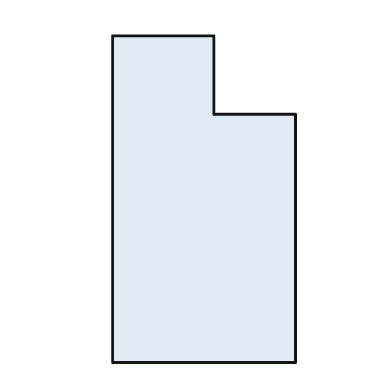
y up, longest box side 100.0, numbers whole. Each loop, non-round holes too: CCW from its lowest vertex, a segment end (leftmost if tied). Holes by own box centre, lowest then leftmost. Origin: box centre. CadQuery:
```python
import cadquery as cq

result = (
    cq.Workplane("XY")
    .moveTo(-28.0, -50.0)
    .lineTo(28.0, -50.0)
    .lineTo(28.0, 26.0)
    .lineTo(3.0, 26.0)
    .lineTo(3.0, 50.0)
    .lineTo(-28.0, 50.0)
    .close()
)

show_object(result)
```